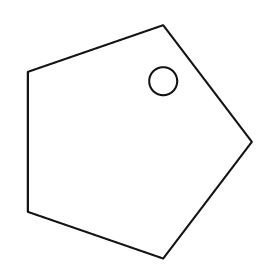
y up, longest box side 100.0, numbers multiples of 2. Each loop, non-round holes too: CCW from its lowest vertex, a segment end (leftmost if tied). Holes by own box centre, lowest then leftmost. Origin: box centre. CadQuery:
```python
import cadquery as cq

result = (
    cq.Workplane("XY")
    .moveTo(10.0, -50.0)
    .lineTo(48.0, 0.0)
    .lineTo(10.0, 50.0)
    .lineTo(-48.0, 30.0)
    .lineTo(-48.0, -30.0)
    .close()
    .moveTo(10.0, 26.0)
    .circle(6.0)
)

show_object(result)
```